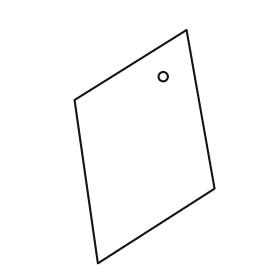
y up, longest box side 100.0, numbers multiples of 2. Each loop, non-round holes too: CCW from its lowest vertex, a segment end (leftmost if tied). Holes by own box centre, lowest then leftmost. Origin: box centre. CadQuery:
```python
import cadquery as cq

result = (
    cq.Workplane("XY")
    .moveTo(-20.0, -50.0)
    .lineTo(30.0, -18.0)
    .lineTo(18.0, 50.0)
    .lineTo(-30.0, 20.0)
    .close()
    .moveTo(8.0, 30.0)
    .circle(2.0)
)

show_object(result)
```